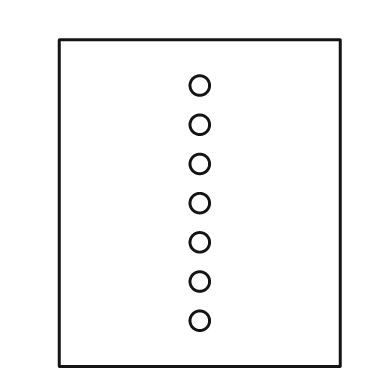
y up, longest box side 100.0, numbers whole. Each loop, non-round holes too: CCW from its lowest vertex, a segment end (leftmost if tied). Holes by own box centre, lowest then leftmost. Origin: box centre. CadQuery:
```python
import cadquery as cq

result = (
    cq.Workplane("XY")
    .moveTo(-43.0, -50.0)
    .lineTo(43.0, -50.0)
    .lineTo(43.0, 50.0)
    .lineTo(-43.0, 50.0)
    .close()
    .moveTo(0.0, -36.0)
    .circle(3.0)
    .moveTo(0.0, -24.0)
    .circle(3.0)
    .moveTo(0.0, -12.0)
    .circle(3.0)
    .moveTo(0.0, 0.0)
    .circle(3.0)
    .moveTo(0.0, 12.0)
    .circle(3.0)
    .moveTo(0.0, 24.0)
    .circle(3.0)
    .moveTo(0.0, 36.0)
    .circle(3.0)
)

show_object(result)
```